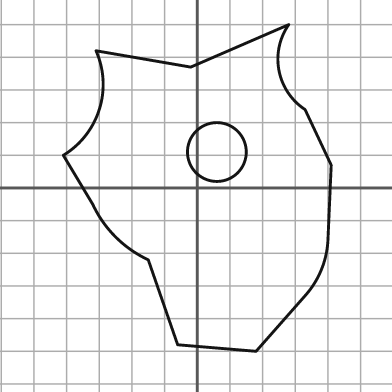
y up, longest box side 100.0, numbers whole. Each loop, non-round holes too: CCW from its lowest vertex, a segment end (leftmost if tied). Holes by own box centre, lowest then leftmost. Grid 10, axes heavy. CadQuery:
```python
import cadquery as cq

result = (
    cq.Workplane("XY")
    .moveTo(18.0, -50.0)
    .lineTo(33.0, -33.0)
    .threePointArc((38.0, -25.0), (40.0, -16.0))
    .lineTo(41.0, 7.0)
    .lineTo(33.0, 24.0)
    .threePointArc((25.0, 36.0), (28.0, 50.0))
    .lineTo(-2.0, 37.0)
    .lineTo(-31.0, 42.0)
    .threePointArc((-30.0, 24.0), (-41.0, 10.0))
    .lineTo(-32.0, -5.0)
    .threePointArc((-25.0, -15.0), (-15.0, -22.0))
    .lineTo(-6.0, -48.0)
    .close()
    .moveTo(6.0, 11.0)
    .circle(9.0)
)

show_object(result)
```